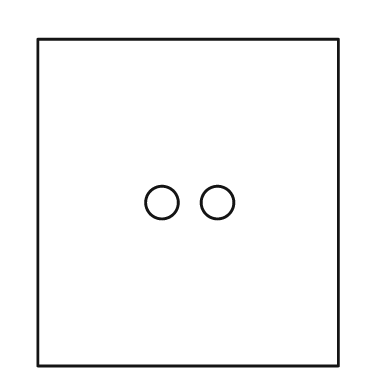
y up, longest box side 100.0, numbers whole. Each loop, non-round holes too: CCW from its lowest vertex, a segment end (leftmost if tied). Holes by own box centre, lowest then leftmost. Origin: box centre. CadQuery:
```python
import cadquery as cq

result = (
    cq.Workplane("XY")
    .moveTo(-46.0, -50.0)
    .lineTo(46.0, -50.0)
    .lineTo(46.0, 50.0)
    .lineTo(-46.0, 50.0)
    .close()
    .moveTo(-8.0, 0.0)
    .circle(5.0)
    .moveTo(9.0, 0.0)
    .circle(5.0)
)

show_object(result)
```